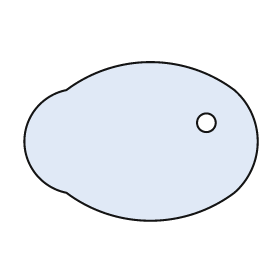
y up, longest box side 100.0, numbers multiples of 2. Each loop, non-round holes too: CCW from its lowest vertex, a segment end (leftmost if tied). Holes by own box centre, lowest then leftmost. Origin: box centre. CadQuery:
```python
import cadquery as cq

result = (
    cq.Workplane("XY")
    .moveTo(-32.0, -22.0)
    .threePointArc((4.0, -34.0), (40.0, -22.0))
    .threePointArc((50.0, 0.0), (40.0, 22.0))
    .threePointArc((4.0, 34.0), (-32.0, 22.0))
    .threePointArc((-50.0, 0.0), (-32.0, -22.0))
    .close()
    .moveTo(28.0, 8.0)
    .circle(4.0)
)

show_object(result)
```